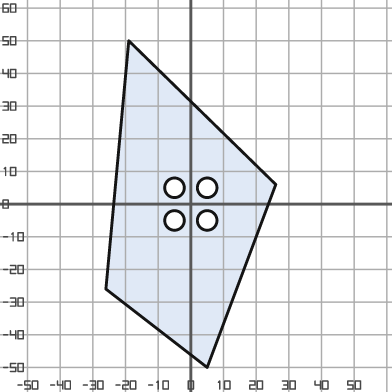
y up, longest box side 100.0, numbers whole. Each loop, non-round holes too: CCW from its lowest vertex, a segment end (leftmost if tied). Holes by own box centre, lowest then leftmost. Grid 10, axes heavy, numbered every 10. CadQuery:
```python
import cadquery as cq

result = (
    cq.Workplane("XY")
    .moveTo(5.0, -50.0)
    .lineTo(26.0, 6.0)
    .lineTo(-19.0, 50.0)
    .lineTo(-26.0, -26.0)
    .close()
    .moveTo(-5.0, -5.0)
    .circle(3.0)
    .moveTo(5.0, -5.0)
    .circle(3.0)
    .moveTo(-5.0, 5.0)
    .circle(3.0)
    .moveTo(5.0, 5.0)
    .circle(3.0)
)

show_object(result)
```